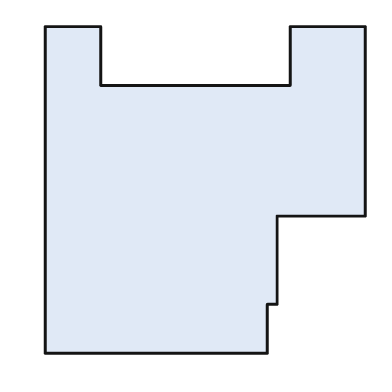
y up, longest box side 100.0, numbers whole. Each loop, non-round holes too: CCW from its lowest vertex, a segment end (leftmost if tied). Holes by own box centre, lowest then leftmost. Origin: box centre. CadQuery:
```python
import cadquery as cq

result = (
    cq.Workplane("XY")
    .moveTo(-49.0, -50.0)
    .lineTo(19.0, -50.0)
    .lineTo(19.0, -35.0)
    .lineTo(22.0, -35.0)
    .lineTo(22.0, -8.0)
    .lineTo(49.0, -8.0)
    .lineTo(49.0, 50.0)
    .lineTo(26.0, 50.0)
    .lineTo(26.0, 32.0)
    .lineTo(-32.0, 32.0)
    .lineTo(-32.0, 50.0)
    .lineTo(-49.0, 50.0)
    .close()
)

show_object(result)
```